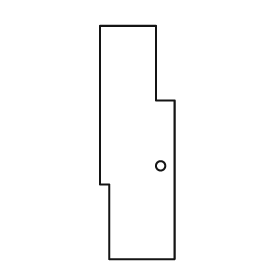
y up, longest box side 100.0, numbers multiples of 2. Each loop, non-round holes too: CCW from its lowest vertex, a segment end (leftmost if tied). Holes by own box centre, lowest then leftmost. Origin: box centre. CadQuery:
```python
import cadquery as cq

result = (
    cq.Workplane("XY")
    .moveTo(-12.0, -50.0)
    .lineTo(16.0, -50.0)
    .lineTo(16.0, 18.0)
    .lineTo(8.0, 18.0)
    .lineTo(8.0, 50.0)
    .lineTo(-16.0, 50.0)
    .lineTo(-16.0, -18.0)
    .lineTo(-12.0, -18.0)
    .close()
    .moveTo(10.0, -10.0)
    .circle(2.0)
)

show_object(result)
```